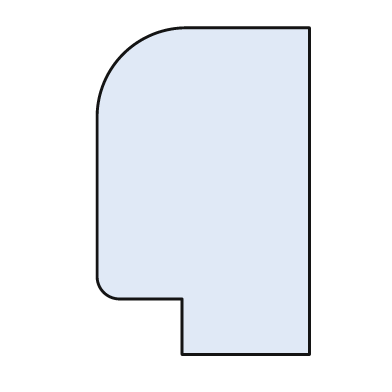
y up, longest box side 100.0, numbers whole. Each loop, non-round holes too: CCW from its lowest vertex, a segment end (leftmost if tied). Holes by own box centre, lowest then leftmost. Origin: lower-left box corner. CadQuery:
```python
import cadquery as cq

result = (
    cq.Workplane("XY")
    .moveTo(26.0, 0.0)
    .lineTo(65.0, 0.0)
    .lineTo(65.0, 100.0)
    .lineTo(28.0, 100.0)
    .threePointArc((8.0, 92.0), (0.0, 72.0))
    .lineTo(0.0, 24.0)
    .threePointArc((2.0, 19.0), (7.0, 17.0))
    .lineTo(26.0, 17.0)
    .close()
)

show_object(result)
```